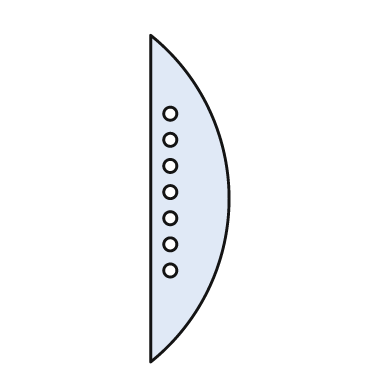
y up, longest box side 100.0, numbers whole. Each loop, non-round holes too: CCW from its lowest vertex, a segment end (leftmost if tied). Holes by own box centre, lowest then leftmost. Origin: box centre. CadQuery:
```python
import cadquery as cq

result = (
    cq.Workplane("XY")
    .moveTo(-12.0, -50.0)
    .threePointArc((12.0, 0.0), (-12.0, 50.0))
    .close()
    .moveTo(-6.0, -22.0)
    .circle(2.0)
    .moveTo(-6.0, -14.0)
    .circle(2.0)
    .moveTo(-6.0, -6.0)
    .circle(2.0)
    .moveTo(-6.0, 2.0)
    .circle(2.0)
    .moveTo(-6.0, 10.0)
    .circle(2.0)
    .moveTo(-6.0, 18.0)
    .circle(2.0)
    .moveTo(-6.0, 26.0)
    .circle(2.0)
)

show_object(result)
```